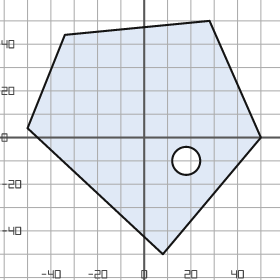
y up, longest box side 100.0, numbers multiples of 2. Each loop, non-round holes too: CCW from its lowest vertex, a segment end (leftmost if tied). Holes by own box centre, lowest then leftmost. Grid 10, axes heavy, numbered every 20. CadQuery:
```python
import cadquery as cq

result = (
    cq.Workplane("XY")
    .moveTo(8.0, -50.0)
    .lineTo(50.0, 0.0)
    .lineTo(28.0, 50.0)
    .lineTo(-34.0, 44.0)
    .lineTo(-50.0, 4.0)
    .close()
    .moveTo(18.0, -10.0)
    .circle(6.0)
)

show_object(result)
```